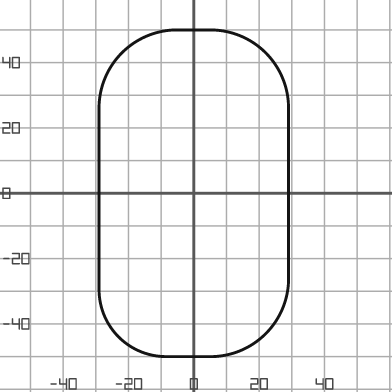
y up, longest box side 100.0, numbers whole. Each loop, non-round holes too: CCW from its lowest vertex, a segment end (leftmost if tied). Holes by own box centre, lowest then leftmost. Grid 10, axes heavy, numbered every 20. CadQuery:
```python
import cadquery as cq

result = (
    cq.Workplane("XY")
    .moveTo(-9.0, -50.0)
    .lineTo(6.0, -50.0)
    .threePointArc((22.0, -43.0), (29.0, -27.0))
    .lineTo(29.0, 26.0)
    .threePointArc((22.0, 43.0), (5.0, 50.0))
    .lineTo(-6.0, 50.0)
    .threePointArc((-22.0, 43.0), (-29.0, 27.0))
    .lineTo(-29.0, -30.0)
    .threePointArc((-23.0, -44.0), (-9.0, -50.0))
    .close()
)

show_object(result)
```